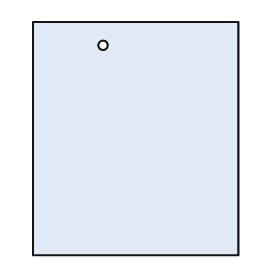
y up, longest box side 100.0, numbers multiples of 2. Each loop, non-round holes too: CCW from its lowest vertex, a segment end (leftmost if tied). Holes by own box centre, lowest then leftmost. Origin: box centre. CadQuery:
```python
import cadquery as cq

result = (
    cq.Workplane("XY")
    .moveTo(-44.0, -50.0)
    .lineTo(44.0, -50.0)
    .lineTo(44.0, 50.0)
    .lineTo(-44.0, 50.0)
    .close()
    .moveTo(-14.0, 40.0)
    .circle(2.0)
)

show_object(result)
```